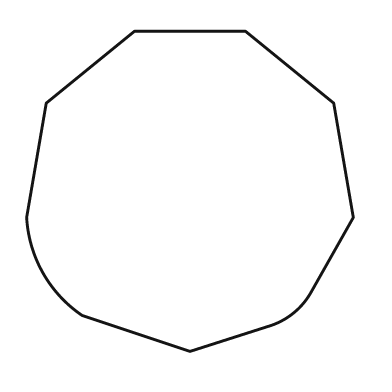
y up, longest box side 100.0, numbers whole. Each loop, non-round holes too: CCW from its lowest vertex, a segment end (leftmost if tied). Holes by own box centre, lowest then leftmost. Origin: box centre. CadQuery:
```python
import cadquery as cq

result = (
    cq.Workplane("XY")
    .moveTo(0.0, -49.0)
    .lineTo(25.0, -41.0)
    .threePointArc((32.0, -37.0), (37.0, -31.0))
    .lineTo(50.0, -8.0)
    .lineTo(44.0, 27.0)
    .lineTo(17.0, 49.0)
    .lineTo(-17.0, 49.0)
    .lineTo(-44.0, 27.0)
    .lineTo(-50.0, -8.0)
    .threePointArc((-45.0, -25.0), (-33.0, -38.0))
    .close()
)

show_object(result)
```